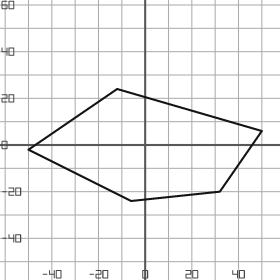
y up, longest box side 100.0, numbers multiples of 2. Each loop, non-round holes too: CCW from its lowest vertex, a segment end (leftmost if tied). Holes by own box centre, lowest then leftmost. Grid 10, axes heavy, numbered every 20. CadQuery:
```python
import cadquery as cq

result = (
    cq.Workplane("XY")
    .moveTo(-6.0, -24.0)
    .lineTo(32.0, -20.0)
    .lineTo(50.0, 6.0)
    .lineTo(-12.0, 24.0)
    .lineTo(-50.0, -2.0)
    .close()
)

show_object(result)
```